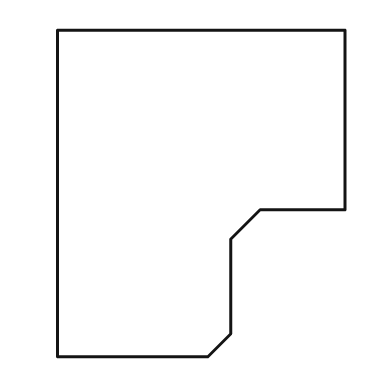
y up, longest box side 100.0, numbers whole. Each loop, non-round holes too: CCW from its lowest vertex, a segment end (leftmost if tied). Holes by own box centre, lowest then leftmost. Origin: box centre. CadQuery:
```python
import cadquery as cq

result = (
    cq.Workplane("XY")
    .moveTo(-44.0, -50.0)
    .lineTo(2.0, -50.0)
    .lineTo(9.0, -43.0)
    .lineTo(9.0, -14.0)
    .lineTo(18.0, -5.0)
    .lineTo(44.0, -5.0)
    .lineTo(44.0, 50.0)
    .lineTo(-44.0, 50.0)
    .close()
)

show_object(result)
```